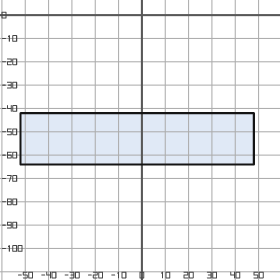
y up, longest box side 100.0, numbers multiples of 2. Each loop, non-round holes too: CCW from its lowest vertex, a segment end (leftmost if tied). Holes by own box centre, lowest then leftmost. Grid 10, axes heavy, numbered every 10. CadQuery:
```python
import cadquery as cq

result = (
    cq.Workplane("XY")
    .moveTo(-52.0, -64.0)
    .lineTo(48.0, -64.0)
    .lineTo(48.0, -42.0)
    .lineTo(-52.0, -42.0)
    .close()
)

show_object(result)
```